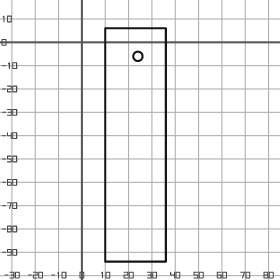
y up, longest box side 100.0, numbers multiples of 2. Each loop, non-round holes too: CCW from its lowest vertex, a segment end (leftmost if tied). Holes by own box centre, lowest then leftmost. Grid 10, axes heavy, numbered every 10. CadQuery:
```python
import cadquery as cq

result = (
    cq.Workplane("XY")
    .moveTo(10.0, -94.0)
    .lineTo(36.0, -94.0)
    .lineTo(36.0, 6.0)
    .lineTo(10.0, 6.0)
    .close()
    .moveTo(24.0, -6.0)
    .circle(2.0)
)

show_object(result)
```